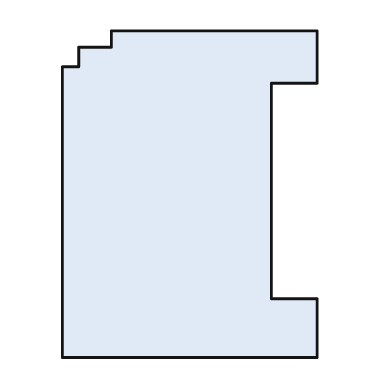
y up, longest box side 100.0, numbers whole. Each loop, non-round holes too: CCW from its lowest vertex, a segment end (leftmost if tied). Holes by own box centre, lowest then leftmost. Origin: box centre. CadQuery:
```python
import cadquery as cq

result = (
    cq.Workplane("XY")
    .moveTo(-39.0, -50.0)
    .lineTo(39.0, -50.0)
    .lineTo(39.0, -32.0)
    .lineTo(25.0, -32.0)
    .lineTo(25.0, 34.0)
    .lineTo(39.0, 34.0)
    .lineTo(39.0, 50.0)
    .lineTo(-24.0, 50.0)
    .lineTo(-24.0, 45.0)
    .lineTo(-34.0, 45.0)
    .lineTo(-34.0, 39.0)
    .lineTo(-39.0, 39.0)
    .close()
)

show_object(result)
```